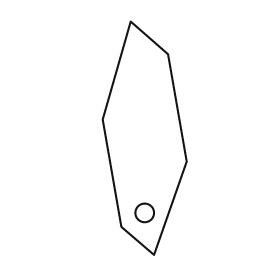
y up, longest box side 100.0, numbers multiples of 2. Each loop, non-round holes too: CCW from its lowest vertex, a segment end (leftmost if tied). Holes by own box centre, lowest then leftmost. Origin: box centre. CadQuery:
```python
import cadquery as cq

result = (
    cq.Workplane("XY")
    .moveTo(4.0, -50.0)
    .lineTo(18.0, -10.0)
    .lineTo(10.0, 36.0)
    .lineTo(-6.0, 50.0)
    .lineTo(-18.0, 8.0)
    .lineTo(-10.0, -38.0)
    .close()
    .moveTo(0.0, -32.0)
    .circle(4.0)
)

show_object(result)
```